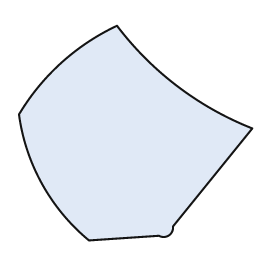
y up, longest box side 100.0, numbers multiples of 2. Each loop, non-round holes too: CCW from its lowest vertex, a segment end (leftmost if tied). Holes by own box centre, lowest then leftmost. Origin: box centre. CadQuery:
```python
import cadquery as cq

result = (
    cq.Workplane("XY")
    .moveTo(-20.0, -46.0)
    .lineTo(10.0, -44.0)
    .threePointArc((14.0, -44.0), (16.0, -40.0))
    .lineTo(50.0, 2.0)
    .threePointArc((18.0, 20.0), (-8.0, 46.0))
    .threePointArc((-32.0, 30.0), (-50.0, 8.0))
    .threePointArc((-40.0, -22.0), (-20.0, -46.0))
    .close()
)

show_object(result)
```